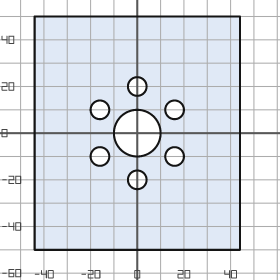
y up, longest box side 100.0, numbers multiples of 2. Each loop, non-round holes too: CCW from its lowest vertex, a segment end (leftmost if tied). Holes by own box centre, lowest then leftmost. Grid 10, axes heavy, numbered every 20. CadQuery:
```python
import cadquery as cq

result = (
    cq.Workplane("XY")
    .moveTo(-44.0, -50.0)
    .lineTo(44.0, -50.0)
    .lineTo(44.0, 50.0)
    .lineTo(-44.0, 50.0)
    .close()
    .moveTo(0.0, -20.0)
    .circle(4.0)
    .moveTo(-16.0, -10.0)
    .circle(4.0)
    .moveTo(16.0, -10.0)
    .circle(4.0)
    .moveTo(0.0, 0.0)
    .circle(10.0)
    .moveTo(-16.0, 10.0)
    .circle(4.0)
    .moveTo(16.0, 10.0)
    .circle(4.0)
    .moveTo(0.0, 20.0)
    .circle(4.0)
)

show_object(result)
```